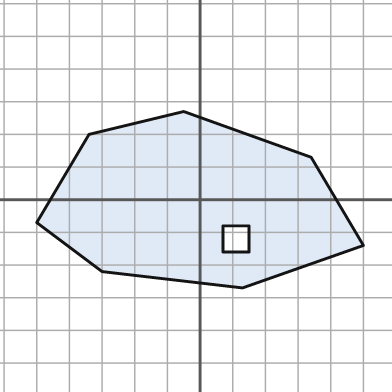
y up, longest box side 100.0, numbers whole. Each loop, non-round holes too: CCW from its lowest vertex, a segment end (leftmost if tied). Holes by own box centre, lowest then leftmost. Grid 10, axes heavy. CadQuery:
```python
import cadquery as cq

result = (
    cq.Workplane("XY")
    .moveTo(13.0, -27.0)
    .lineTo(50.0, -14.0)
    .lineTo(34.0, 13.0)
    .lineTo(-5.0, 27.0)
    .lineTo(-34.0, 20.0)
    .lineTo(-50.0, -7.0)
    .lineTo(-30.0, -22.0)
    .close()
    .moveTo(7.0, -16.0)
    .lineTo(15.0, -16.0)
    .lineTo(15.0, -8.0)
    .lineTo(7.0, -8.0)
    .close()
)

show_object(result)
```